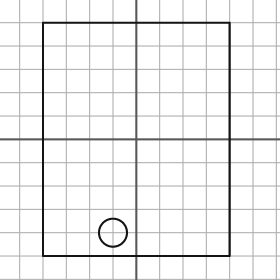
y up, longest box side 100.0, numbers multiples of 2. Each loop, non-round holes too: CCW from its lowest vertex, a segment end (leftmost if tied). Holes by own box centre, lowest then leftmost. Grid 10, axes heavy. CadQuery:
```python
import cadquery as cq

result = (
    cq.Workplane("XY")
    .moveTo(-40.0, -50.0)
    .lineTo(40.0, -50.0)
    .lineTo(40.0, 50.0)
    .lineTo(-40.0, 50.0)
    .close()
    .moveTo(-10.0, -40.0)
    .circle(6.0)
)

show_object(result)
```